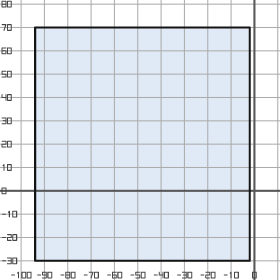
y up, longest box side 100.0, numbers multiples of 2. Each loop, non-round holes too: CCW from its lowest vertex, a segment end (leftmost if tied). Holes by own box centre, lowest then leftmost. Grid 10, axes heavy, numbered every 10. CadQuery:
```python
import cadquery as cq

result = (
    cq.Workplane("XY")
    .moveTo(-94.0, -30.0)
    .lineTo(-2.0, -30.0)
    .lineTo(-2.0, 70.0)
    .lineTo(-94.0, 70.0)
    .close()
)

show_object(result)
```